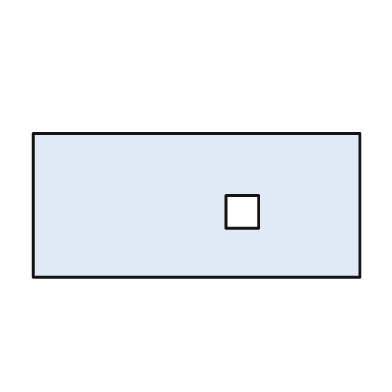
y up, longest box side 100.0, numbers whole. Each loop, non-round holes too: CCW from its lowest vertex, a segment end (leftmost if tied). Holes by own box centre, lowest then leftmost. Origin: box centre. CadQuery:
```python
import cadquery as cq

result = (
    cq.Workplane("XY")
    .moveTo(-50.0, -22.0)
    .lineTo(50.0, -22.0)
    .lineTo(50.0, 22.0)
    .lineTo(-50.0, 22.0)
    .close()
    .moveTo(9.0, -7.0)
    .lineTo(19.0, -7.0)
    .lineTo(19.0, 3.0)
    .lineTo(9.0, 3.0)
    .close()
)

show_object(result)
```